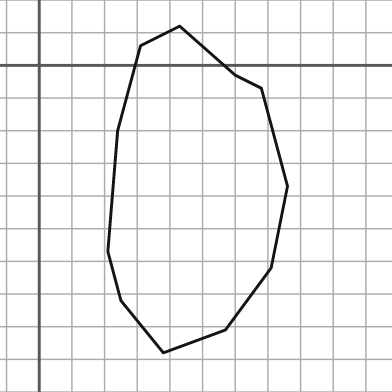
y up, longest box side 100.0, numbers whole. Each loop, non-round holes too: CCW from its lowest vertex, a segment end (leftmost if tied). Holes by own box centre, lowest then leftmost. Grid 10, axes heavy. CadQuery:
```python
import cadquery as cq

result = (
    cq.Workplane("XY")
    .moveTo(38.0, -88.0)
    .lineTo(57.0, -81.0)
    .lineTo(71.0, -62.0)
    .lineTo(76.0, -37.0)
    .lineTo(68.0, -7.0)
    .lineTo(60.0, -3.0)
    .lineTo(43.0, 12.0)
    .lineTo(31.0, 6.0)
    .lineTo(24.0, -20.0)
    .lineTo(21.0, -57.0)
    .lineTo(25.0, -72.0)
    .close()
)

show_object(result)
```